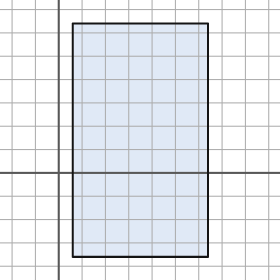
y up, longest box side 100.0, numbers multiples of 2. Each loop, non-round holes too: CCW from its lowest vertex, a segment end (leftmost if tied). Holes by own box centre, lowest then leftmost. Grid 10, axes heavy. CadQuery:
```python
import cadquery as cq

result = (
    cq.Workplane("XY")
    .moveTo(6.0, -36.0)
    .lineTo(64.0, -36.0)
    .lineTo(64.0, 64.0)
    .lineTo(6.0, 64.0)
    .close()
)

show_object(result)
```